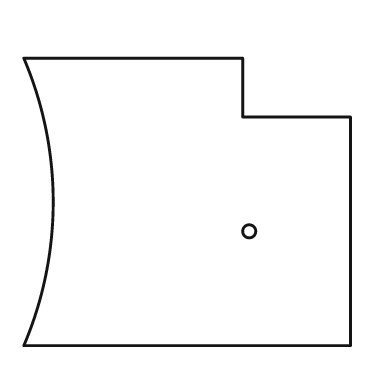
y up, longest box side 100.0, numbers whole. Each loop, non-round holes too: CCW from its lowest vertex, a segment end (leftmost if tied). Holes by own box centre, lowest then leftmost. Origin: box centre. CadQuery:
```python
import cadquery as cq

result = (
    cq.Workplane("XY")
    .moveTo(-50.0, -44.0)
    .lineTo(50.0, -44.0)
    .lineTo(50.0, 26.0)
    .lineTo(17.0, 26.0)
    .lineTo(17.0, 44.0)
    .lineTo(-50.0, 44.0)
    .threePointArc((-41.0, 0.0), (-50.0, -44.0))
    .close()
    .moveTo(19.0, -9.0)
    .circle(2.0)
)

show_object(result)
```